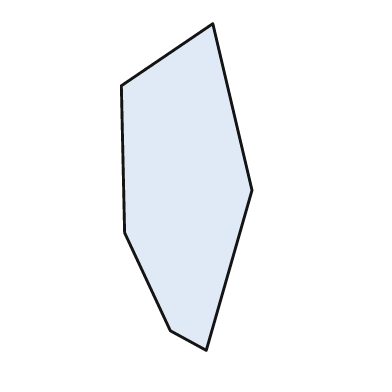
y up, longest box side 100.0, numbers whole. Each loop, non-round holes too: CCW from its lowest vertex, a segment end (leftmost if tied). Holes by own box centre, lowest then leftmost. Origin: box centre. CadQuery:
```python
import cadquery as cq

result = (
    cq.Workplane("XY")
    .moveTo(6.0, -50.0)
    .lineTo(20.0, -1.0)
    .lineTo(8.0, 50.0)
    .lineTo(-20.0, 31.0)
    .lineTo(-19.0, -14.0)
    .lineTo(-5.0, -44.0)
    .close()
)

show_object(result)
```